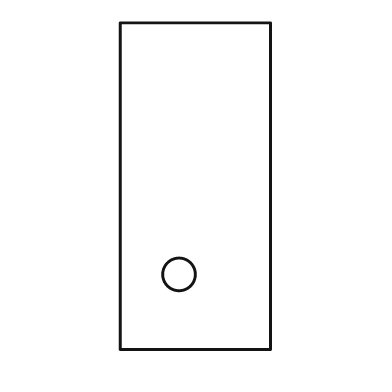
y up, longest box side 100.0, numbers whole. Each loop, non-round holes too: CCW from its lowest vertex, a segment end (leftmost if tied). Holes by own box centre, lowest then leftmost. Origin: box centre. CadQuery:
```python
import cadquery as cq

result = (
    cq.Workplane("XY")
    .moveTo(-23.0, -50.0)
    .lineTo(23.0, -50.0)
    .lineTo(23.0, 50.0)
    .lineTo(-23.0, 50.0)
    .close()
    .moveTo(-5.0, -27.0)
    .circle(5.0)
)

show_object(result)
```